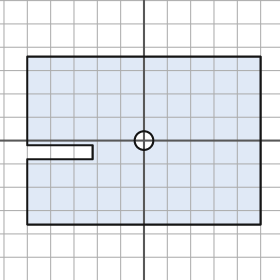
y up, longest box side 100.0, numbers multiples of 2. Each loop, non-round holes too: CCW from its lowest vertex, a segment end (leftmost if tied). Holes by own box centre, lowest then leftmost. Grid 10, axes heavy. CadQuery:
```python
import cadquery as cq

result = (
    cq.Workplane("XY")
    .moveTo(-50.0, -36.0)
    .lineTo(50.0, -36.0)
    .lineTo(50.0, 36.0)
    .lineTo(-50.0, 36.0)
    .lineTo(-50.0, -2.0)
    .lineTo(-22.0, -2.0)
    .lineTo(-22.0, -8.0)
    .lineTo(-50.0, -8.0)
    .close()
    .moveTo(0.0, 0.0)
    .circle(4.0)
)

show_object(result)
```